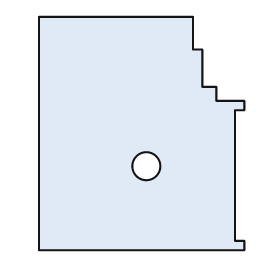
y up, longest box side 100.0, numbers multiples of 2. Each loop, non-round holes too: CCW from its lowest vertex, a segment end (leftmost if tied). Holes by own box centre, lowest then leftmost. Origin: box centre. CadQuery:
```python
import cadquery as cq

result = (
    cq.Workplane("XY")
    .moveTo(-44.0, -50.0)
    .lineTo(44.0, -50.0)
    .lineTo(44.0, -46.0)
    .lineTo(40.0, -46.0)
    .lineTo(40.0, 10.0)
    .lineTo(44.0, 10.0)
    .lineTo(44.0, 14.0)
    .lineTo(32.0, 14.0)
    .lineTo(32.0, 20.0)
    .lineTo(26.0, 20.0)
    .lineTo(26.0, 36.0)
    .lineTo(22.0, 36.0)
    .lineTo(22.0, 50.0)
    .lineTo(-44.0, 50.0)
    .close()
    .moveTo(2.0, -14.0)
    .circle(6.0)
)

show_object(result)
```